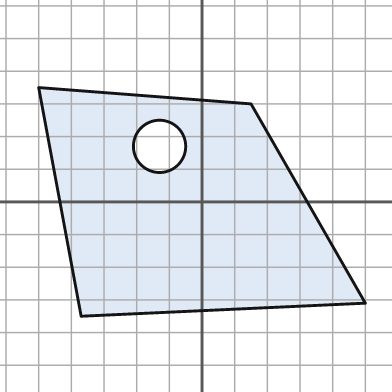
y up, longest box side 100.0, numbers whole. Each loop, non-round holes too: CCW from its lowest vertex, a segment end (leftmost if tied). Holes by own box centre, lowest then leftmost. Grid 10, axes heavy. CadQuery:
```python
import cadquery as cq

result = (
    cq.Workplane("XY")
    .moveTo(-37.0, -35.0)
    .lineTo(50.0, -31.0)
    .lineTo(15.0, 30.0)
    .lineTo(-50.0, 35.0)
    .close()
    .moveTo(-13.0, 17.0)
    .circle(8.0)
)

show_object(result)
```